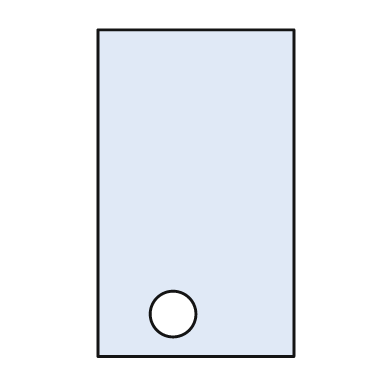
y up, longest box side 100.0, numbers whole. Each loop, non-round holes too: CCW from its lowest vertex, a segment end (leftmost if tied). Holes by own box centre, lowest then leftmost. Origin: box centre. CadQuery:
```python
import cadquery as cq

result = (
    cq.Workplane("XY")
    .moveTo(-30.0, -50.0)
    .lineTo(30.0, -50.0)
    .lineTo(30.0, 50.0)
    .lineTo(-30.0, 50.0)
    .close()
    .moveTo(-7.0, -37.0)
    .circle(7.0)
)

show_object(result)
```